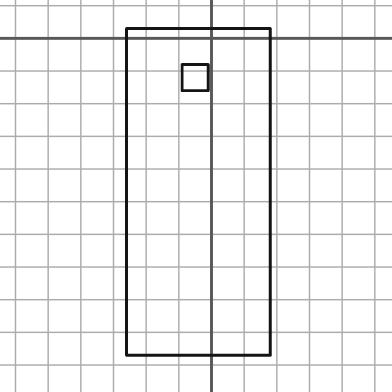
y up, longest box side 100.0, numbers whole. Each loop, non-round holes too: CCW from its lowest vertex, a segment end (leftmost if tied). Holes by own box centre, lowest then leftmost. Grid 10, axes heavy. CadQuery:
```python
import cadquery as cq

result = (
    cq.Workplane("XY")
    .moveTo(-26.0, -97.0)
    .lineTo(18.0, -97.0)
    .lineTo(18.0, 3.0)
    .lineTo(-26.0, 3.0)
    .close()
    .moveTo(-9.0, -16.0)
    .lineTo(-1.0, -16.0)
    .lineTo(-1.0, -8.0)
    .lineTo(-9.0, -8.0)
    .close()
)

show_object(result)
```